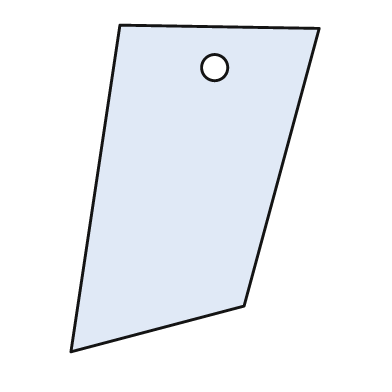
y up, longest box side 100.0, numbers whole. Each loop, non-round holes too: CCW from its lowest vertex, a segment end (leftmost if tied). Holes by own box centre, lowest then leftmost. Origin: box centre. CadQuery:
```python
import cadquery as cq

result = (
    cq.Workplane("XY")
    .moveTo(-38.0, -50.0)
    .lineTo(15.0, -36.0)
    .lineTo(38.0, 49.0)
    .lineTo(-23.0, 50.0)
    .close()
    .moveTo(6.0, 37.0)
    .circle(4.0)
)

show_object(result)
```